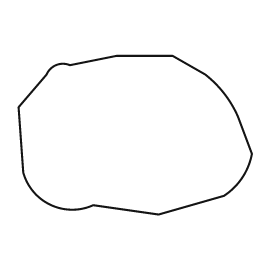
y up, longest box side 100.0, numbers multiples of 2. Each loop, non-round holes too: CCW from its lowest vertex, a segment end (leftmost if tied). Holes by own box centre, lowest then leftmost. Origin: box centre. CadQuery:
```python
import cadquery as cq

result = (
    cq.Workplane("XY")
    .moveTo(10.0, -34.0)
    .lineTo(38.0, -26.0)
    .threePointArc((46.0, -18.0), (50.0, -8.0))
    .lineTo(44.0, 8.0)
    .threePointArc((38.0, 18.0), (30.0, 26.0))
    .lineTo(16.0, 34.0)
    .lineTo(-8.0, 34.0)
    .lineTo(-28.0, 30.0)
    .threePointArc((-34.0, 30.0), (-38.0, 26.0))
    .lineTo(-50.0, 12.0)
    .lineTo(-48.0, -16.0)
    .threePointArc((-36.0, -30.0), (-18.0, -30.0))
    .close()
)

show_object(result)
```